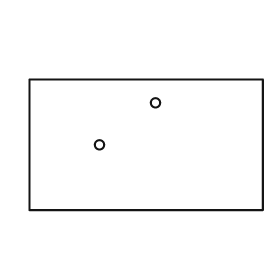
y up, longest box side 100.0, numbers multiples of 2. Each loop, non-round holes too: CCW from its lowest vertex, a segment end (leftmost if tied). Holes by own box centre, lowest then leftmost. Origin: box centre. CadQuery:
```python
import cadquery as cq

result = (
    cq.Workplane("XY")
    .moveTo(-50.0, -28.0)
    .lineTo(50.0, -28.0)
    .lineTo(50.0, 28.0)
    .lineTo(-50.0, 28.0)
    .close()
    .moveTo(-20.0, 0.0)
    .circle(2.0)
    .moveTo(4.0, 18.0)
    .circle(2.0)
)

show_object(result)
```